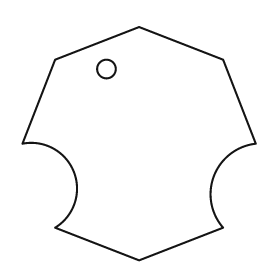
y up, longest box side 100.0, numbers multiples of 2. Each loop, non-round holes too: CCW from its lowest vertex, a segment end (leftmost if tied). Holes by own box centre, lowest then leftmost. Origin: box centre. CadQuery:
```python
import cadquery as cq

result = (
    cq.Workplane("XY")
    .moveTo(0.0, -50.0)
    .lineTo(36.0, -36.0)
    .threePointArc((32.0, -14.0), (50.0, 0.0))
    .lineTo(36.0, 36.0)
    .lineTo(0.0, 50.0)
    .lineTo(-36.0, 36.0)
    .lineTo(-50.0, 0.0)
    .threePointArc((-28.0, -12.0), (-36.0, -36.0))
    .close()
    .moveTo(-14.0, 32.0)
    .circle(4.0)
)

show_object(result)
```